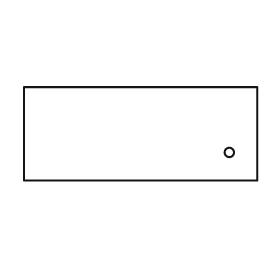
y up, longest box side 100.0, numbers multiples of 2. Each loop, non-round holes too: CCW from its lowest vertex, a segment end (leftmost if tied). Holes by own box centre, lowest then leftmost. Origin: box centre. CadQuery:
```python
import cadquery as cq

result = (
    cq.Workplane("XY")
    .moveTo(-50.0, -20.0)
    .lineTo(50.0, -20.0)
    .lineTo(50.0, 20.0)
    .lineTo(-50.0, 20.0)
    .close()
    .moveTo(38.0, -8.0)
    .circle(2.0)
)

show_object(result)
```